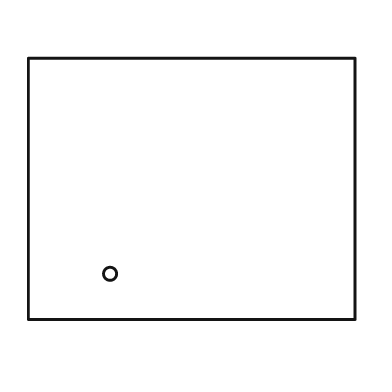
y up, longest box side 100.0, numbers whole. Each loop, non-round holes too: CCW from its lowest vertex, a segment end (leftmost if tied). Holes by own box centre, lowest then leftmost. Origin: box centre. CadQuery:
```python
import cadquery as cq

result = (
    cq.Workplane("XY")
    .moveTo(-50.0, -40.0)
    .lineTo(50.0, -40.0)
    .lineTo(50.0, 40.0)
    .lineTo(-50.0, 40.0)
    .close()
    .moveTo(-25.0, -26.0)
    .circle(2.0)
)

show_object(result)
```